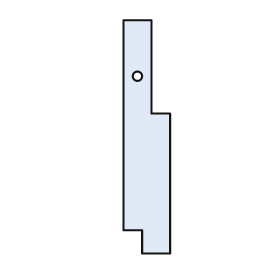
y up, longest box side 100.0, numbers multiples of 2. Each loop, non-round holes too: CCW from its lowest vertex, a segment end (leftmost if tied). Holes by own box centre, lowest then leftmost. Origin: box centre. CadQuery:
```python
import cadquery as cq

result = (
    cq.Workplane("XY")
    .moveTo(-2.0, -50.0)
    .lineTo(10.0, -50.0)
    .lineTo(10.0, 10.0)
    .lineTo(2.0, 10.0)
    .lineTo(2.0, 50.0)
    .lineTo(-10.0, 50.0)
    .lineTo(-10.0, -40.0)
    .lineTo(-2.0, -40.0)
    .close()
    .moveTo(-4.0, 26.0)
    .circle(2.0)
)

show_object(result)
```